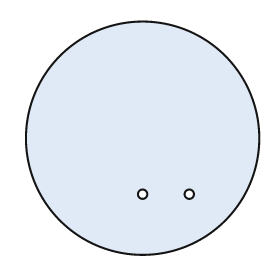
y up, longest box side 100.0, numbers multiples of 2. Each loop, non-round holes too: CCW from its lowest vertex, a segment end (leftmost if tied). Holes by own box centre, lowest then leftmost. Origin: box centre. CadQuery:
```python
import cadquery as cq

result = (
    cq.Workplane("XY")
    .moveTo(0.0, 0.0)
    .circle(50.0)
    .moveTo(0.0, -24.0)
    .circle(2.0)
    .moveTo(20.0, -24.0)
    .circle(2.0)
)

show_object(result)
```